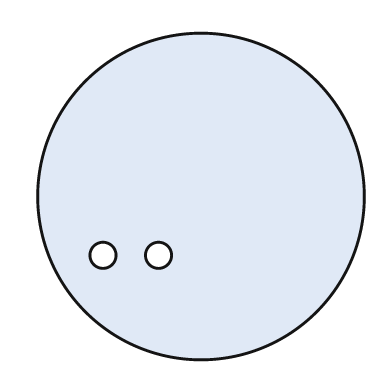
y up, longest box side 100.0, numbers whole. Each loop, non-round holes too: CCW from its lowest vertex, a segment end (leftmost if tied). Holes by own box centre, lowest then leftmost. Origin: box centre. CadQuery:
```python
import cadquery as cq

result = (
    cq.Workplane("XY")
    .moveTo(0.0, 0.0)
    .circle(50.0)
    .moveTo(-30.0, -18.0)
    .circle(4.0)
    .moveTo(-13.0, -18.0)
    .circle(4.0)
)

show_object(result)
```